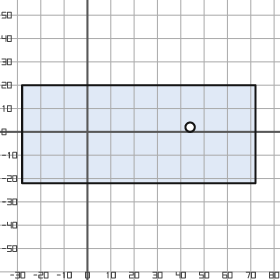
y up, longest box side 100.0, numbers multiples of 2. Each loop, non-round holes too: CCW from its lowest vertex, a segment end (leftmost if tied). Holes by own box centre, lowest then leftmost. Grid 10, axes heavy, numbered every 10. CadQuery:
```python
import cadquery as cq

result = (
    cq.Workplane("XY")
    .moveTo(-28.0, -22.0)
    .lineTo(72.0, -22.0)
    .lineTo(72.0, 20.0)
    .lineTo(-28.0, 20.0)
    .close()
    .moveTo(44.0, 2.0)
    .circle(2.0)
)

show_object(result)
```